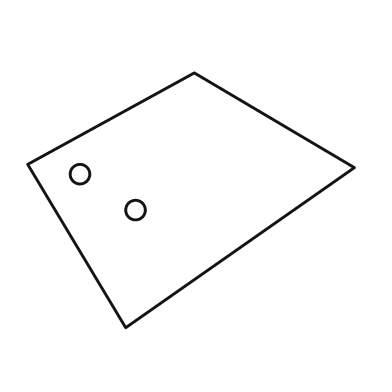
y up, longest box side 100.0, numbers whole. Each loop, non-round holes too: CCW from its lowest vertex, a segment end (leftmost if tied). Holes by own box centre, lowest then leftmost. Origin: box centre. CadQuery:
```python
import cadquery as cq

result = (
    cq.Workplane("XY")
    .moveTo(-20.0, -39.0)
    .lineTo(50.0, 10.0)
    .lineTo(1.0, 39.0)
    .lineTo(-50.0, 11.0)
    .close()
    .moveTo(-17.0, -3.0)
    .circle(3.0)
    .moveTo(-34.0, 8.0)
    .circle(3.0)
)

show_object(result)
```